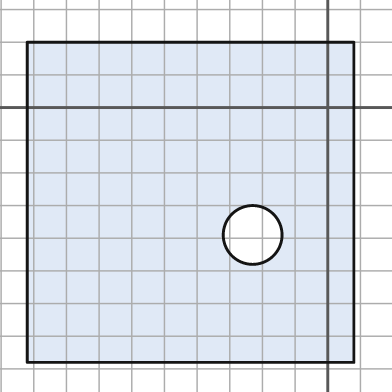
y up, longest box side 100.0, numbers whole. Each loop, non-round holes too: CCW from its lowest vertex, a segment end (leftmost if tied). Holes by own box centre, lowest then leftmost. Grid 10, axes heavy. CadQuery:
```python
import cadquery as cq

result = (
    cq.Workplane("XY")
    .moveTo(-92.0, -78.0)
    .lineTo(8.0, -78.0)
    .lineTo(8.0, 20.0)
    .lineTo(-92.0, 20.0)
    .close()
    .moveTo(-23.0, -39.0)
    .circle(9.0)
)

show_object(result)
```